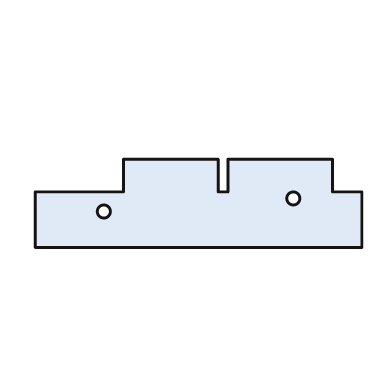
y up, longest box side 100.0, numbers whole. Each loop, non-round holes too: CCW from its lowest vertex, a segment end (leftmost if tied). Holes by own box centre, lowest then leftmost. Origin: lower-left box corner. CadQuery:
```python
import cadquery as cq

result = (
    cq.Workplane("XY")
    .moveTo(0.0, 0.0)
    .lineTo(100.0, 0.0)
    .lineTo(100.0, 17.0)
    .lineTo(91.0, 17.0)
    .lineTo(91.0, 27.0)
    .lineTo(59.0, 27.0)
    .lineTo(59.0, 17.0)
    .lineTo(56.0, 17.0)
    .lineTo(56.0, 27.0)
    .lineTo(27.0, 27.0)
    .lineTo(27.0, 17.0)
    .lineTo(0.0, 17.0)
    .close()
    .moveTo(21.0, 11.0)
    .circle(2.0)
    .moveTo(79.0, 15.0)
    .circle(2.0)
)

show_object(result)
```